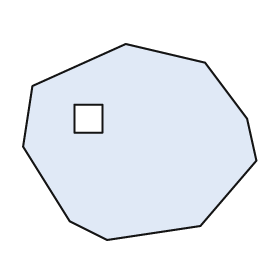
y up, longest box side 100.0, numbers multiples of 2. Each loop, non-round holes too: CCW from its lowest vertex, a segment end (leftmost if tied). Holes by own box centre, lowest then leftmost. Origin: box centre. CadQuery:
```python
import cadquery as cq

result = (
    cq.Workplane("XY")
    .moveTo(-14.0, -42.0)
    .lineTo(26.0, -36.0)
    .lineTo(50.0, -8.0)
    .lineTo(46.0, 10.0)
    .lineTo(28.0, 34.0)
    .lineTo(-6.0, 42.0)
    .lineTo(-46.0, 24.0)
    .lineTo(-50.0, -2.0)
    .lineTo(-30.0, -34.0)
    .close()
    .moveTo(-28.0, 4.0)
    .lineTo(-16.0, 4.0)
    .lineTo(-16.0, 16.0)
    .lineTo(-28.0, 16.0)
    .close()
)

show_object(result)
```